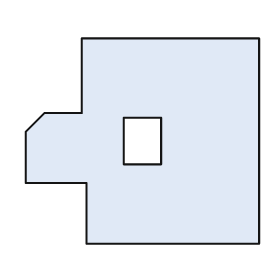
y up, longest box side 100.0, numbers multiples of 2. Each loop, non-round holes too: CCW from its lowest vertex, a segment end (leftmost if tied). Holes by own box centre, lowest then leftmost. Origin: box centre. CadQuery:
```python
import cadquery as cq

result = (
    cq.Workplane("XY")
    .moveTo(-24.0, -44.0)
    .lineTo(50.0, -44.0)
    .lineTo(50.0, 44.0)
    .lineTo(-26.0, 44.0)
    .lineTo(-26.0, 12.0)
    .lineTo(-42.0, 12.0)
    .lineTo(-50.0, 4.0)
    .lineTo(-50.0, -18.0)
    .lineTo(-24.0, -18.0)
    .close()
    .moveTo(-8.0, -10.0)
    .lineTo(8.0, -10.0)
    .lineTo(8.0, 10.0)
    .lineTo(-8.0, 10.0)
    .close()
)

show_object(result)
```